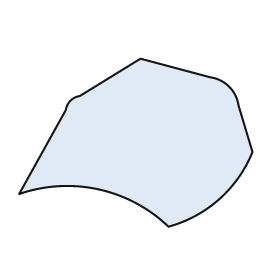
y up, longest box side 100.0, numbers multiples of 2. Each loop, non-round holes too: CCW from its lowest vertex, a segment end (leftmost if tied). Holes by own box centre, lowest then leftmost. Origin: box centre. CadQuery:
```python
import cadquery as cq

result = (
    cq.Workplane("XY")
    .moveTo(14.0, -36.0)
    .threePointArc((36.0, -24.0), (50.0, -4.0))
    .lineTo(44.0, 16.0)
    .threePointArc((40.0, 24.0), (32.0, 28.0))
    .lineTo(2.0, 36.0)
    .lineTo(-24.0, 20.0)
    .threePointArc((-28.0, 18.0), (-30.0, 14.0))
    .lineTo(-50.0, -22.0)
    .threePointArc((-16.0, -20.0), (14.0, -36.0))
    .close()
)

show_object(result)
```